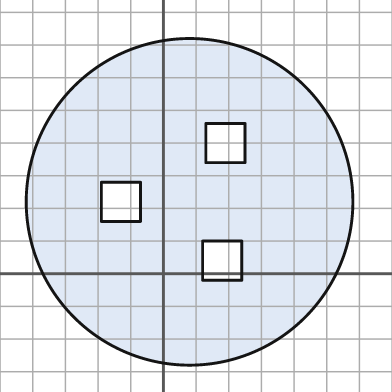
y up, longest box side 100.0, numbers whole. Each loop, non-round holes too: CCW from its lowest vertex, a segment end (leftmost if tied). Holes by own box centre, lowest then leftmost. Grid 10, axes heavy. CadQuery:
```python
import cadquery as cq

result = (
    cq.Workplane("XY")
    .moveTo(8.0, 22.0)
    .circle(50.0)
    .moveTo(12.0, -2.0)
    .lineTo(24.0, -2.0)
    .lineTo(24.0, 10.0)
    .lineTo(12.0, 10.0)
    .close()
    .moveTo(-19.0, 16.0)
    .lineTo(-7.0, 16.0)
    .lineTo(-7.0, 28.0)
    .lineTo(-19.0, 28.0)
    .close()
    .moveTo(13.0, 34.0)
    .lineTo(25.0, 34.0)
    .lineTo(25.0, 46.0)
    .lineTo(13.0, 46.0)
    .close()
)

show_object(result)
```